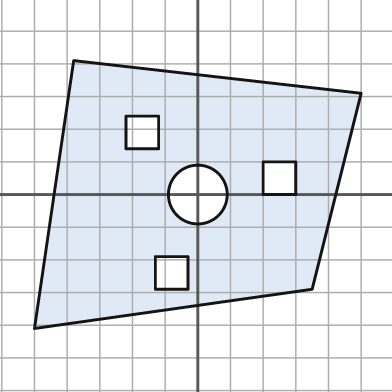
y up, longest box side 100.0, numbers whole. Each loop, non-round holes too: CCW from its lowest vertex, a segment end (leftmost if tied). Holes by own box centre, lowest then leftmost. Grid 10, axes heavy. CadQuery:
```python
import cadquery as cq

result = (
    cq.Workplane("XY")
    .moveTo(-50.0, -41.0)
    .lineTo(35.0, -29.0)
    .lineTo(50.0, 31.0)
    .lineTo(-38.0, 41.0)
    .close()
    .moveTo(-13.0, -29.0)
    .lineTo(-3.0, -29.0)
    .lineTo(-3.0, -19.0)
    .lineTo(-13.0, -19.0)
    .close()
    .moveTo(0.0, 0.0)
    .circle(9.0)
    .moveTo(20.0, 0.0)
    .lineTo(30.0, 0.0)
    .lineTo(30.0, 10.0)
    .lineTo(20.0, 10.0)
    .close()
    .moveTo(-22.0, 14.0)
    .lineTo(-12.0, 14.0)
    .lineTo(-12.0, 24.0)
    .lineTo(-22.0, 24.0)
    .close()
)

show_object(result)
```